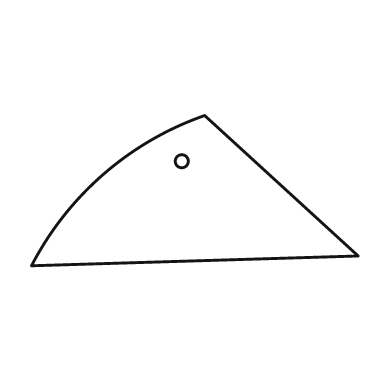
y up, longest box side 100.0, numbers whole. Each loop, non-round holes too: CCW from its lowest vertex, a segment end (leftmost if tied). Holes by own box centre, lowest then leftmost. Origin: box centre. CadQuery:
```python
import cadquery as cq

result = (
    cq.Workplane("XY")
    .moveTo(-50.0, -23.0)
    .lineTo(50.0, -20.0)
    .lineTo(3.0, 23.0)
    .threePointArc((-28.0, 5.0), (-50.0, -23.0))
    .close()
    .moveTo(-4.0, 9.0)
    .circle(2.0)
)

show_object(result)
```